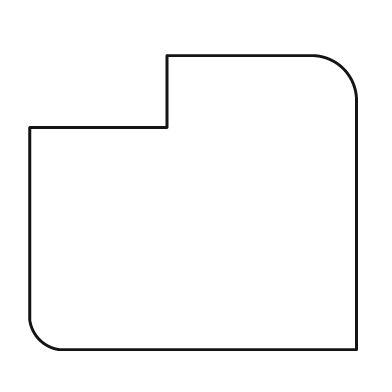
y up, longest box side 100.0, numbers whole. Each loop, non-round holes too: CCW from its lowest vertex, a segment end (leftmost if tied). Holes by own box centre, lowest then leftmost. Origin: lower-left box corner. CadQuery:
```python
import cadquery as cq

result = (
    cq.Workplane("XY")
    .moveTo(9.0, 0.0)
    .lineTo(100.0, 0.0)
    .lineTo(100.0, 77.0)
    .threePointArc((96.0, 86.0), (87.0, 90.0))
    .lineTo(42.0, 90.0)
    .lineTo(42.0, 68.0)
    .lineTo(0.0, 68.0)
    .lineTo(0.0, 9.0)
    .threePointArc((3.0, 3.0), (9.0, 0.0))
    .close()
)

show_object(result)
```